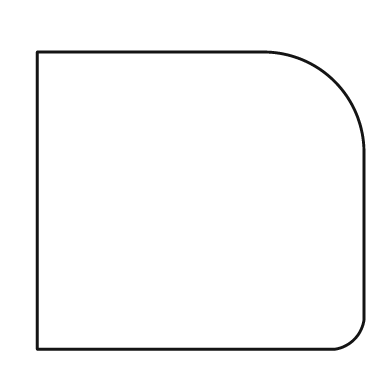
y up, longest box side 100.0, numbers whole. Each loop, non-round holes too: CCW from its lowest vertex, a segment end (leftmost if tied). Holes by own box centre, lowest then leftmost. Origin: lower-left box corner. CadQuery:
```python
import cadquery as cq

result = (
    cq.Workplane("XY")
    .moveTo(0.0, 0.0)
    .lineTo(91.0, 0.0)
    .threePointArc((97.0, 3.0), (100.0, 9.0))
    .lineTo(100.0, 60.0)
    .threePointArc((91.0, 82.0), (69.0, 91.0))
    .lineTo(0.0, 91.0)
    .close()
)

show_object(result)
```